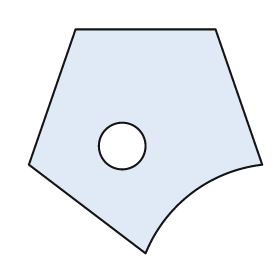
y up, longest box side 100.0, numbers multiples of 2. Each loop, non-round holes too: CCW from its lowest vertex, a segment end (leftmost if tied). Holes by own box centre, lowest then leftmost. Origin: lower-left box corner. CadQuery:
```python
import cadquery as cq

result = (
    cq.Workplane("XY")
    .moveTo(50.0, 0.0)
    .threePointArc((70.0, 26.0), (100.0, 38.0))
    .lineTo(80.0, 96.0)
    .lineTo(20.0, 96.0)
    .lineTo(0.0, 38.0)
    .close()
    .moveTo(40.0, 46.0)
    .circle(10.0)
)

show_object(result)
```